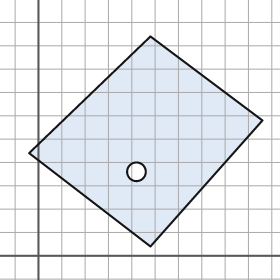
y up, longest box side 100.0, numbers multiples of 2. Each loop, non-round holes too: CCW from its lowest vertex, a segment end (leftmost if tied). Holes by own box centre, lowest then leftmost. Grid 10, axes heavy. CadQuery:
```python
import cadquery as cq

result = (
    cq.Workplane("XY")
    .moveTo(48.0, 4.0)
    .lineTo(96.0, 58.0)
    .lineTo(48.0, 94.0)
    .lineTo(-4.0, 44.0)
    .close()
    .moveTo(42.0, 36.0)
    .circle(4.0)
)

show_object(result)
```